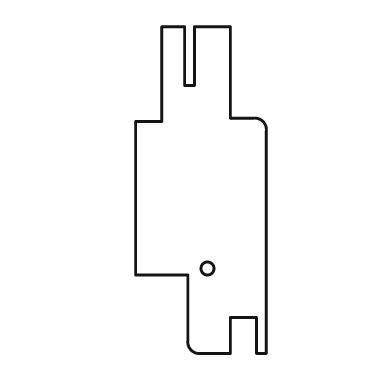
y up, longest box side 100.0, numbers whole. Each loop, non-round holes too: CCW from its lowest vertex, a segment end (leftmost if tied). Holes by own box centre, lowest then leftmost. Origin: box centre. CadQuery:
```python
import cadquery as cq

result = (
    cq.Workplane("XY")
    .moveTo(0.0, -50.0)
    .lineTo(9.0, -50.0)
    .lineTo(9.0, -39.0)
    .lineTo(17.0, -39.0)
    .lineTo(17.0, -50.0)
    .lineTo(20.0, -50.0)
    .lineTo(20.0, 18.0)
    .threePointArc((19.0, 21.0), (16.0, 22.0))
    .lineTo(9.0, 22.0)
    .lineTo(9.0, 50.0)
    .lineTo(-2.0, 50.0)
    .lineTo(-2.0, 32.0)
    .lineTo(-5.0, 32.0)
    .lineTo(-5.0, 50.0)
    .lineTo(-12.0, 50.0)
    .lineTo(-12.0, 21.0)
    .lineTo(-20.0, 21.0)
    .lineTo(-20.0, -26.0)
    .lineTo(-4.0, -26.0)
    .lineTo(-4.0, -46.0)
    .threePointArc((-3.0, -49.0), (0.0, -50.0))
    .close()
    .moveTo(2.0, -24.0)
    .circle(2.0)
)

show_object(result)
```